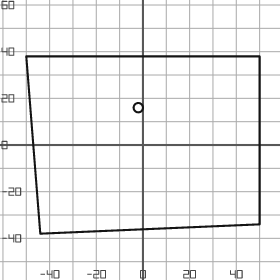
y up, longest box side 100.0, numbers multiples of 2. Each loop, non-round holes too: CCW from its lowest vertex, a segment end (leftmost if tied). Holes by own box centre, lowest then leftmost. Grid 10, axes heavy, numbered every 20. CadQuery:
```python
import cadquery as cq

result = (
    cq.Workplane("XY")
    .moveTo(-44.0, -38.0)
    .lineTo(50.0, -34.0)
    .lineTo(50.0, 38.0)
    .lineTo(-50.0, 38.0)
    .close()
    .moveTo(-2.0, 16.0)
    .circle(2.0)
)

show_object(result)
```